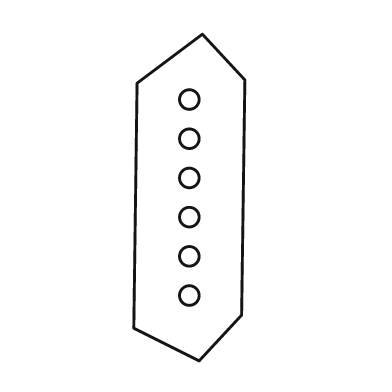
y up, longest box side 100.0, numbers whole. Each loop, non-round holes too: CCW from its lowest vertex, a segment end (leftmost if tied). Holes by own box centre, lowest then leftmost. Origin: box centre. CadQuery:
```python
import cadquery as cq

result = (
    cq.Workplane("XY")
    .moveTo(3.0, -50.0)
    .lineTo(16.0, -36.0)
    .lineTo(17.0, 36.0)
    .lineTo(4.0, 50.0)
    .lineTo(-16.0, 35.0)
    .lineTo(-17.0, -40.0)
    .close()
    .moveTo(0.0, -30.0)
    .circle(3.0)
    .moveTo(0.0, -18.0)
    .circle(3.0)
    .moveTo(0.0, -6.0)
    .circle(3.0)
    .moveTo(0.0, 6.0)
    .circle(3.0)
    .moveTo(0.0, 18.0)
    .circle(3.0)
    .moveTo(0.0, 30.0)
    .circle(3.0)
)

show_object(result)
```